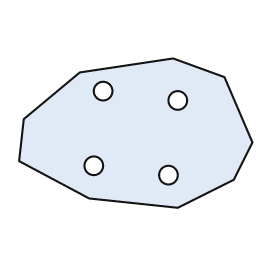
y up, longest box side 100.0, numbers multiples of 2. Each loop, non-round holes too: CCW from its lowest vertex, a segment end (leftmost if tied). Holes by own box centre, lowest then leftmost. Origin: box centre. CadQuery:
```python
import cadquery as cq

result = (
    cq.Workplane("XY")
    .moveTo(18.0, -32.0)
    .lineTo(42.0, -20.0)
    .lineTo(50.0, -4.0)
    .lineTo(38.0, 24.0)
    .lineTo(16.0, 32.0)
    .lineTo(-24.0, 26.0)
    .lineTo(-48.0, 6.0)
    .lineTo(-50.0, -12.0)
    .lineTo(-20.0, -28.0)
    .close()
    .moveTo(14.0, -18.0)
    .circle(4.0)
    .moveTo(-18.0, -14.0)
    .circle(4.0)
    .moveTo(18.0, 14.0)
    .circle(4.0)
    .moveTo(-14.0, 18.0)
    .circle(4.0)
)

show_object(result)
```